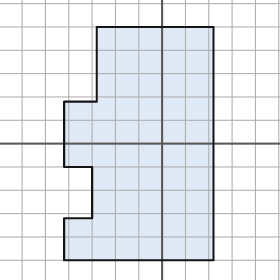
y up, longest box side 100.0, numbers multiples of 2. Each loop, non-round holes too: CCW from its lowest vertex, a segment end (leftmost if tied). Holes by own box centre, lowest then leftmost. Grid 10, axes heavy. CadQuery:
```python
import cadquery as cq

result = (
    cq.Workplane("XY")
    .moveTo(-42.0, -50.0)
    .lineTo(22.0, -50.0)
    .lineTo(22.0, 50.0)
    .lineTo(-28.0, 50.0)
    .lineTo(-28.0, 18.0)
    .lineTo(-42.0, 18.0)
    .lineTo(-42.0, -10.0)
    .lineTo(-30.0, -10.0)
    .lineTo(-30.0, -32.0)
    .lineTo(-42.0, -32.0)
    .close()
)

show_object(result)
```